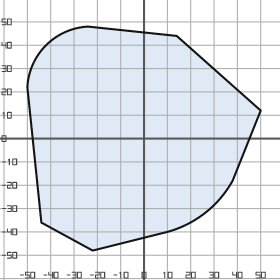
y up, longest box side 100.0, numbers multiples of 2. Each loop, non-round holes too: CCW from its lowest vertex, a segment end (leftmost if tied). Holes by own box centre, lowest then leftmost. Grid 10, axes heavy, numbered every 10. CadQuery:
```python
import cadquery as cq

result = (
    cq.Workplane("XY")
    .moveTo(-22.0, -48.0)
    .lineTo(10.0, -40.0)
    .threePointArc((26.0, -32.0), (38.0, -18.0))
    .lineTo(50.0, 12.0)
    .lineTo(14.0, 44.0)
    .lineTo(-24.0, 48.0)
    .threePointArc((-42.0, 40.0), (-50.0, 22.0))
    .lineTo(-44.0, -36.0)
    .close()
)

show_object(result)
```